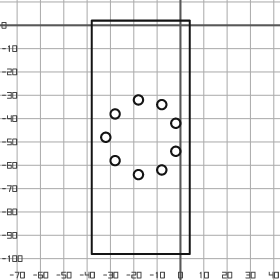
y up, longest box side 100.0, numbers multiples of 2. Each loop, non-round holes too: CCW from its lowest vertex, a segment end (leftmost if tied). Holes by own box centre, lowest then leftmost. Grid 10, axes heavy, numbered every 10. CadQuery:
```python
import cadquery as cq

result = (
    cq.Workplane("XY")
    .moveTo(-38.0, -98.0)
    .lineTo(4.0, -98.0)
    .lineTo(4.0, 2.0)
    .lineTo(-38.0, 2.0)
    .close()
    .moveTo(-18.0, -64.0)
    .circle(2.0)
    .moveTo(-8.0, -62.0)
    .circle(2.0)
    .moveTo(-28.0, -58.0)
    .circle(2.0)
    .moveTo(-2.0, -54.0)
    .circle(2.0)
    .moveTo(-32.0, -48.0)
    .circle(2.0)
    .moveTo(-2.0, -42.0)
    .circle(2.0)
    .moveTo(-28.0, -38.0)
    .circle(2.0)
    .moveTo(-8.0, -34.0)
    .circle(2.0)
    .moveTo(-18.0, -32.0)
    .circle(2.0)
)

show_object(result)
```